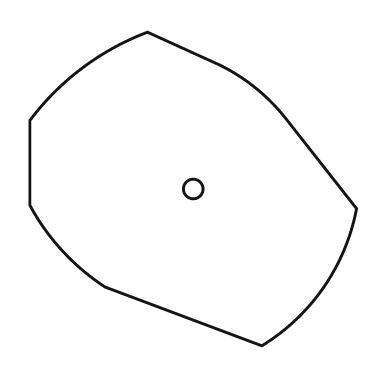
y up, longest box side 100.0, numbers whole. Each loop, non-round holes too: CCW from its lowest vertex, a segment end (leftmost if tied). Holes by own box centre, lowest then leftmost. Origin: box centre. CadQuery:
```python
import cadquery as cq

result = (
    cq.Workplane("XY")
    .moveTo(21.0, -48.0)
    .threePointArc((40.0, -30.0), (50.0, -6.0))
    .lineTo(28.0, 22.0)
    .threePointArc((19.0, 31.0), (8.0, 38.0))
    .lineTo(-14.0, 48.0)
    .threePointArc((-34.0, 37.0), (-50.0, 21.0))
    .lineTo(-50.0, -5.0)
    .threePointArc((-40.0, -19.0), (-27.0, -30.0))
    .close()
    .moveTo(0.0, 0.0)
    .circle(3.0)
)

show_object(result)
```